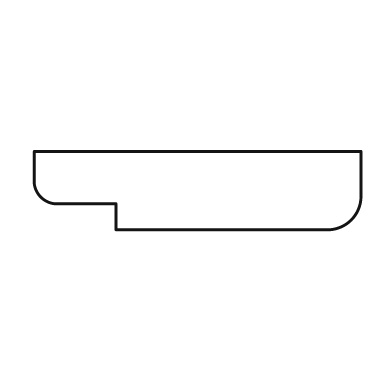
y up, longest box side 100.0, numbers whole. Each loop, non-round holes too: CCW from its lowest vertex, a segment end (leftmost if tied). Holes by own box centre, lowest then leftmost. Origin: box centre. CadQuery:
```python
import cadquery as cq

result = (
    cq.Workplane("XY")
    .moveTo(-25.0, -12.0)
    .lineTo(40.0, -12.0)
    .threePointArc((47.0, -9.0), (50.0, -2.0))
    .lineTo(50.0, 12.0)
    .lineTo(-50.0, 12.0)
    .lineTo(-50.0, 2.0)
    .threePointArc((-48.0, -2.0), (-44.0, -4.0))
    .lineTo(-25.0, -4.0)
    .close()
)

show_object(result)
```